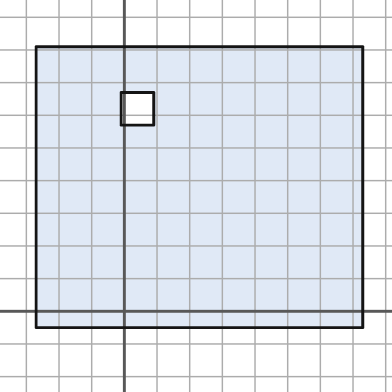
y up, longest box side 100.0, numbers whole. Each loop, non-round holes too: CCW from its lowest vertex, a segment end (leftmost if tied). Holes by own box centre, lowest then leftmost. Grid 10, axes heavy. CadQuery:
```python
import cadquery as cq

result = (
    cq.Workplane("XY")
    .moveTo(-27.0, -5.0)
    .lineTo(73.0, -5.0)
    .lineTo(73.0, 81.0)
    .lineTo(-27.0, 81.0)
    .close()
    .moveTo(-1.0, 57.0)
    .lineTo(9.0, 57.0)
    .lineTo(9.0, 67.0)
    .lineTo(-1.0, 67.0)
    .close()
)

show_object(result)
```